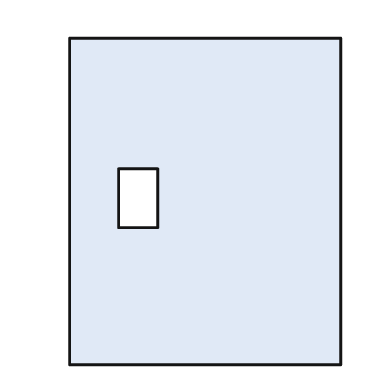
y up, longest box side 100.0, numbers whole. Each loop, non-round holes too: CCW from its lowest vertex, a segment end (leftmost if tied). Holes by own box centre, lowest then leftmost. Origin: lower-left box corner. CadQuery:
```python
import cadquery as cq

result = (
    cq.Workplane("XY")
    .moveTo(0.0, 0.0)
    .lineTo(83.0, 0.0)
    .lineTo(83.0, 100.0)
    .lineTo(0.0, 100.0)
    .close()
    .moveTo(15.0, 42.0)
    .lineTo(27.0, 42.0)
    .lineTo(27.0, 60.0)
    .lineTo(15.0, 60.0)
    .close()
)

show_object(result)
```